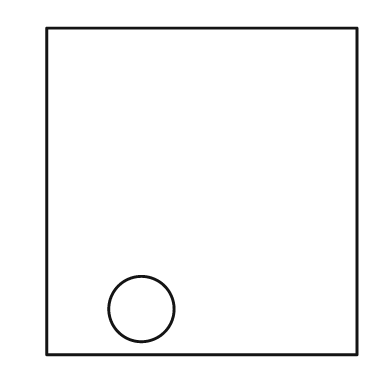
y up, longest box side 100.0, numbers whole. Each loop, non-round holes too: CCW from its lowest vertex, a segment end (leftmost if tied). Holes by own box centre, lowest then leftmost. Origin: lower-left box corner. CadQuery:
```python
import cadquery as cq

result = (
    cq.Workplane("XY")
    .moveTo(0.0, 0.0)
    .lineTo(95.0, 0.0)
    .lineTo(95.0, 100.0)
    .lineTo(0.0, 100.0)
    .close()
    .moveTo(29.0, 14.0)
    .circle(10.0)
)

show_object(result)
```